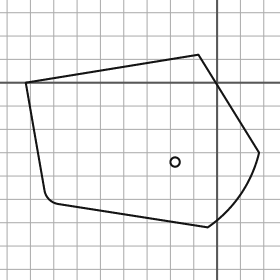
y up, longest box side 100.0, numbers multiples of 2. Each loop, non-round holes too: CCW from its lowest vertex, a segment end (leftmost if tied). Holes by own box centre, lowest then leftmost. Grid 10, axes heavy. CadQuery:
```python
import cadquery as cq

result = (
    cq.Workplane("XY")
    .moveTo(-4.0, -62.0)
    .threePointArc((10.0, -48.0), (18.0, -30.0))
    .lineTo(-8.0, 12.0)
    .lineTo(-82.0, 0.0)
    .lineTo(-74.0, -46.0)
    .threePointArc((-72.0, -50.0), (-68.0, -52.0))
    .close()
    .moveTo(-18.0, -34.0)
    .circle(2.0)
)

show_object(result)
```